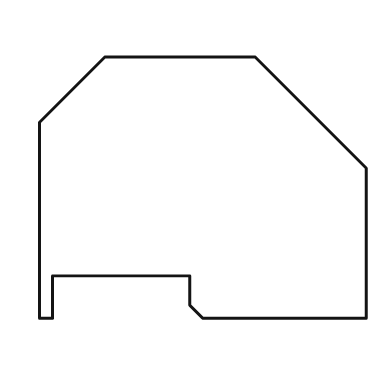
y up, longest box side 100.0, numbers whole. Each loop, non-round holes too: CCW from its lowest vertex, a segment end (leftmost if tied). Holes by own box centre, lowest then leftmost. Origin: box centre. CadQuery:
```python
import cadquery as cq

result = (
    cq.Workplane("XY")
    .moveTo(-50.0, -40.0)
    .lineTo(-46.0, -40.0)
    .lineTo(-46.0, -27.0)
    .lineTo(-4.0, -27.0)
    .lineTo(-4.0, -36.0)
    .lineTo(0.0, -40.0)
    .lineTo(50.0, -40.0)
    .lineTo(50.0, 6.0)
    .lineTo(16.0, 40.0)
    .lineTo(-30.0, 40.0)
    .lineTo(-50.0, 20.0)
    .close()
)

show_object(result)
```